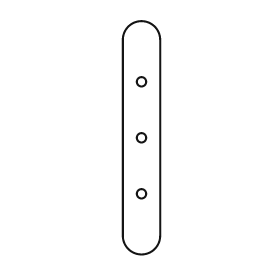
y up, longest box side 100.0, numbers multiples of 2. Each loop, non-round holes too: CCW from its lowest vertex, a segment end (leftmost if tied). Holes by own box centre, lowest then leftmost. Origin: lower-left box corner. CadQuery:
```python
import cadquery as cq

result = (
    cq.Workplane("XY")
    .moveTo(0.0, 8.0)
    .threePointArc((8.0, 0.0), (16.0, 8.0))
    .lineTo(16.0, 92.0)
    .threePointArc((8.0, 100.0), (0.0, 92.0))
    .close()
    .moveTo(8.0, 26.0)
    .circle(2.0)
    .moveTo(8.0, 50.0)
    .circle(2.0)
    .moveTo(8.0, 74.0)
    .circle(2.0)
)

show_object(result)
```